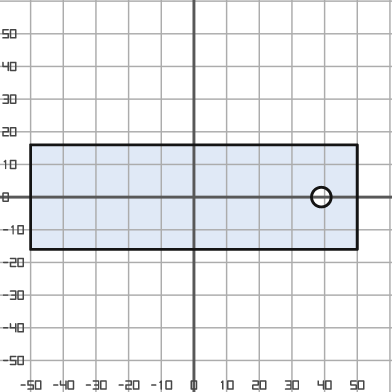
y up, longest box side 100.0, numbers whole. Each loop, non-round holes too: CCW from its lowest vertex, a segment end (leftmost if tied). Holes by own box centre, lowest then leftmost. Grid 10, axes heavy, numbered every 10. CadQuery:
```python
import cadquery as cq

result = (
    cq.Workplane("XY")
    .moveTo(-50.0, -16.0)
    .lineTo(50.0, -16.0)
    .lineTo(50.0, 16.0)
    .lineTo(-50.0, 16.0)
    .close()
    .moveTo(39.0, 0.0)
    .circle(3.0)
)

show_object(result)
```